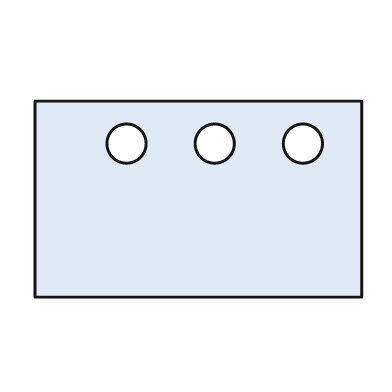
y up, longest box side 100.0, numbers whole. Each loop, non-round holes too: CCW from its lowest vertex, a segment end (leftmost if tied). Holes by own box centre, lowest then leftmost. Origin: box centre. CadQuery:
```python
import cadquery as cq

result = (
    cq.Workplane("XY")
    .moveTo(-50.0, -30.0)
    .lineTo(50.0, -30.0)
    .lineTo(50.0, 30.0)
    .lineTo(-50.0, 30.0)
    .close()
    .moveTo(-22.0, 17.0)
    .circle(6.0)
    .moveTo(5.0, 17.0)
    .circle(6.0)
    .moveTo(32.0, 17.0)
    .circle(6.0)
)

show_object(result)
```